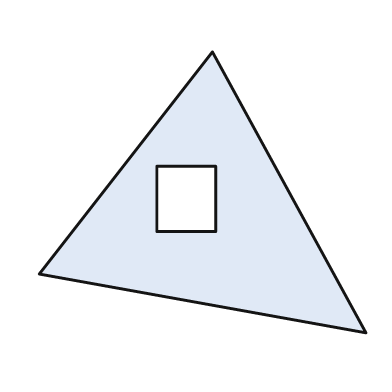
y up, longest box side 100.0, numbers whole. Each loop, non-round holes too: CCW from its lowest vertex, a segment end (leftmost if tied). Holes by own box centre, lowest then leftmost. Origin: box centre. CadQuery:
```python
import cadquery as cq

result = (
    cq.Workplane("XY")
    .moveTo(50.0, -43.0)
    .lineTo(3.0, 43.0)
    .lineTo(-50.0, -25.0)
    .close()
    .moveTo(-14.0, -12.0)
    .lineTo(4.0, -12.0)
    .lineTo(4.0, 8.0)
    .lineTo(-14.0, 8.0)
    .close()
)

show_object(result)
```